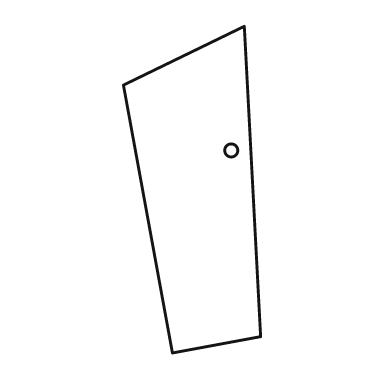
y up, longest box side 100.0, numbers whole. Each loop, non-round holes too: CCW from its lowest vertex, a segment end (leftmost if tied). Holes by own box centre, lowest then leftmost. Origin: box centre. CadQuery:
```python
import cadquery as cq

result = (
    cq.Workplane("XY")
    .moveTo(-6.0, -50.0)
    .lineTo(21.0, -45.0)
    .lineTo(16.0, 50.0)
    .lineTo(-21.0, 32.0)
    .close()
    .moveTo(12.0, 12.0)
    .circle(2.0)
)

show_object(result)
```